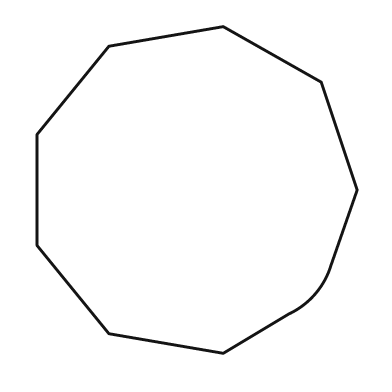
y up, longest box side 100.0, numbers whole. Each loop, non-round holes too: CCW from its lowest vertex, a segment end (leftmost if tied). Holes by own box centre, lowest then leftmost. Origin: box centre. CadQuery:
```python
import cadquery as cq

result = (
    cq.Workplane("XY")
    .moveTo(8.0, -50.0)
    .lineTo(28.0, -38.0)
    .threePointArc((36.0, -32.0), (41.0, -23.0))
    .lineTo(49.0, 0.0)
    .lineTo(38.0, 33.0)
    .lineTo(8.0, 50.0)
    .lineTo(-27.0, 44.0)
    .lineTo(-49.0, 17.0)
    .lineTo(-49.0, -17.0)
    .lineTo(-27.0, -44.0)
    .close()
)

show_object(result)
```